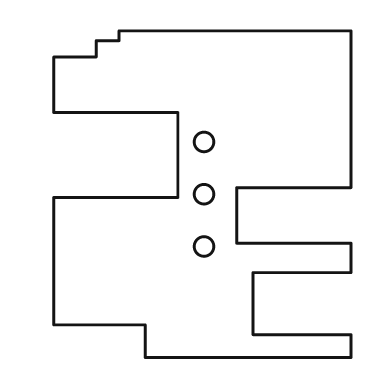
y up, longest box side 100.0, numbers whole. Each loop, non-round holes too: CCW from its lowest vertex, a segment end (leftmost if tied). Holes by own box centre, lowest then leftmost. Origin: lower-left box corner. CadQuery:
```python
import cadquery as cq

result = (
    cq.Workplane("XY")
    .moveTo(28.0, 0.0)
    .lineTo(91.0, 0.0)
    .lineTo(91.0, 7.0)
    .lineTo(61.0, 7.0)
    .lineTo(61.0, 26.0)
    .lineTo(91.0, 26.0)
    .lineTo(91.0, 35.0)
    .lineTo(56.0, 35.0)
    .lineTo(56.0, 52.0)
    .lineTo(91.0, 52.0)
    .lineTo(91.0, 100.0)
    .lineTo(20.0, 100.0)
    .lineTo(20.0, 97.0)
    .lineTo(13.0, 97.0)
    .lineTo(13.0, 92.0)
    .lineTo(0.0, 92.0)
    .lineTo(0.0, 75.0)
    .lineTo(38.0, 75.0)
    .lineTo(38.0, 49.0)
    .lineTo(0.0, 49.0)
    .lineTo(0.0, 10.0)
    .lineTo(28.0, 10.0)
    .close()
    .moveTo(46.0, 34.0)
    .circle(3.0)
    .moveTo(46.0, 50.0)
    .circle(3.0)
    .moveTo(46.0, 66.0)
    .circle(3.0)
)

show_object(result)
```